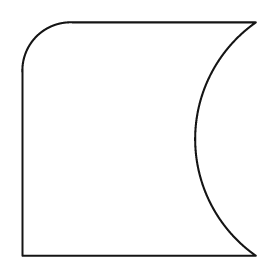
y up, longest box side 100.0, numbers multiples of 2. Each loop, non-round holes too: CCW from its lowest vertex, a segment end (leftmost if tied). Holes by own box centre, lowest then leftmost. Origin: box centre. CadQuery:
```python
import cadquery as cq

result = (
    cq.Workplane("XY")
    .moveTo(-50.0, -50.0)
    .lineTo(50.0, -50.0)
    .threePointArc((24.0, 0.0), (50.0, 50.0))
    .lineTo(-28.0, 50.0)
    .threePointArc((-44.0, 44.0), (-50.0, 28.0))
    .close()
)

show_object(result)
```